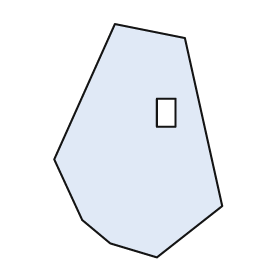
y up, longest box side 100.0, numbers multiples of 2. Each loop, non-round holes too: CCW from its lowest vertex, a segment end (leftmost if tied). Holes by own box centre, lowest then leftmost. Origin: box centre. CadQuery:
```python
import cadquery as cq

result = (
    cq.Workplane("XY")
    .moveTo(8.0, -50.0)
    .lineTo(36.0, -28.0)
    .lineTo(20.0, 44.0)
    .lineTo(-10.0, 50.0)
    .lineTo(-36.0, -8.0)
    .lineTo(-24.0, -34.0)
    .lineTo(-12.0, -44.0)
    .close()
    .moveTo(8.0, 6.0)
    .lineTo(16.0, 6.0)
    .lineTo(16.0, 18.0)
    .lineTo(8.0, 18.0)
    .close()
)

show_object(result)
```